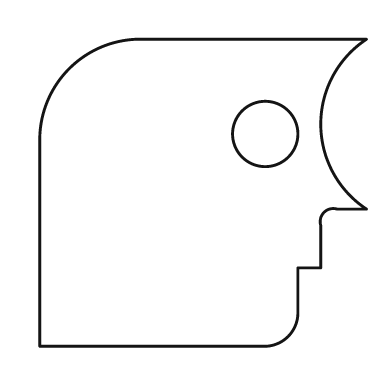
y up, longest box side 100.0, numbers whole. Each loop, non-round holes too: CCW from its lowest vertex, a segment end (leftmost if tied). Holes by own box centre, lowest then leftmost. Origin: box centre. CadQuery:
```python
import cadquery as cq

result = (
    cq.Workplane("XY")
    .moveTo(-50.0, -47.0)
    .lineTo(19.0, -47.0)
    .threePointArc((26.0, -44.0), (29.0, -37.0))
    .lineTo(29.0, -23.0)
    .lineTo(36.0, -23.0)
    .lineTo(36.0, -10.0)
    .threePointArc((37.0, -6.0), (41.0, -5.0))
    .lineTo(50.0, -5.0)
    .threePointArc((36.0, 21.0), (50.0, 47.0))
    .lineTo(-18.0, 47.0)
    .threePointArc((-41.0, 38.0), (-50.0, 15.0))
    .close()
    .moveTo(19.0, 18.0)
    .circle(10.0)
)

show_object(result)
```